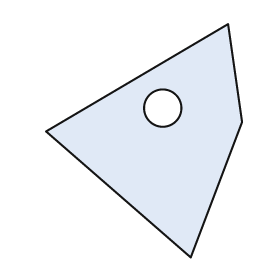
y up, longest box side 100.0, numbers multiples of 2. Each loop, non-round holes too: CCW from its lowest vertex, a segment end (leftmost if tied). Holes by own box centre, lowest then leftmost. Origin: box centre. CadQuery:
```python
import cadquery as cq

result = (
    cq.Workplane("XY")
    .moveTo(20.0, -50.0)
    .lineTo(42.0, 8.0)
    .lineTo(36.0, 50.0)
    .lineTo(-42.0, 4.0)
    .close()
    .moveTo(8.0, 14.0)
    .circle(8.0)
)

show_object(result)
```